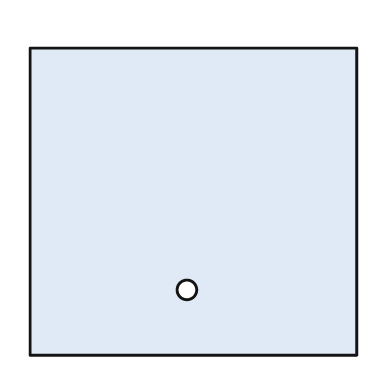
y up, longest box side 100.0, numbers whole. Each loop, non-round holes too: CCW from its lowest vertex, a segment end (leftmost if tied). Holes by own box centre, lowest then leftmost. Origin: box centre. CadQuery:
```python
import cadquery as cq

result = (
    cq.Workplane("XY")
    .moveTo(-50.0, -47.0)
    .lineTo(50.0, -47.0)
    .lineTo(50.0, 47.0)
    .lineTo(-50.0, 47.0)
    .close()
    .moveTo(-2.0, -27.0)
    .circle(3.0)
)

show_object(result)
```